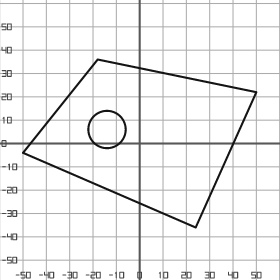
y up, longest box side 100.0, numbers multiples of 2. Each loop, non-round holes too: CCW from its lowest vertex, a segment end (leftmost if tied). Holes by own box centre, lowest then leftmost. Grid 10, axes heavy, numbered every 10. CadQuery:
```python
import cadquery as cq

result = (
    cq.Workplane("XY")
    .moveTo(24.0, -36.0)
    .lineTo(50.0, 22.0)
    .lineTo(-18.0, 36.0)
    .lineTo(-50.0, -4.0)
    .close()
    .moveTo(-14.0, 6.0)
    .circle(8.0)
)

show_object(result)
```